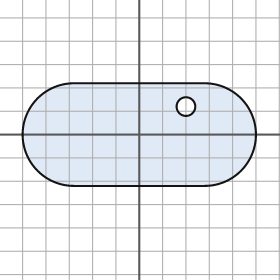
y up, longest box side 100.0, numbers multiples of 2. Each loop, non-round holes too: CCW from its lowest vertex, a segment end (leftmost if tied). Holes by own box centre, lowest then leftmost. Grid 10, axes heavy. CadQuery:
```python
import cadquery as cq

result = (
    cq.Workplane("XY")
    .moveTo(-28.0, -22.0)
    .lineTo(28.0, -22.0)
    .threePointArc((50.0, 0.0), (28.0, 22.0))
    .lineTo(-28.0, 22.0)
    .threePointArc((-50.0, 0.0), (-28.0, -22.0))
    .close()
    .moveTo(20.0, 12.0)
    .circle(4.0)
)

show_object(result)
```